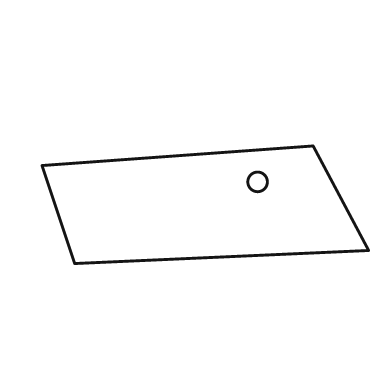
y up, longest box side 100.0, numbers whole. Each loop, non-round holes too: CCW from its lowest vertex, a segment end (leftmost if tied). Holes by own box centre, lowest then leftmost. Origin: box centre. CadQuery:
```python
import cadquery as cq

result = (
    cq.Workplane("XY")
    .moveTo(-40.0, -18.0)
    .lineTo(50.0, -14.0)
    .lineTo(33.0, 18.0)
    .lineTo(-50.0, 12.0)
    .close()
    .moveTo(16.0, 7.0)
    .circle(3.0)
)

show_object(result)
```